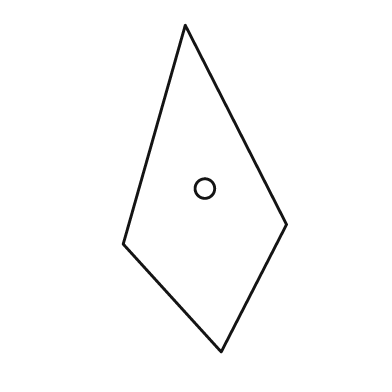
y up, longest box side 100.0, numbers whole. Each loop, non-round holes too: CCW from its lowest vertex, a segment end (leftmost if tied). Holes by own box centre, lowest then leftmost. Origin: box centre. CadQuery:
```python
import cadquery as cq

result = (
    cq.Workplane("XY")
    .moveTo(5.0, -50.0)
    .lineTo(25.0, -11.0)
    .lineTo(-6.0, 50.0)
    .lineTo(-25.0, -17.0)
    .close()
    .moveTo(0.0, 0.0)
    .circle(3.0)
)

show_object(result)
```